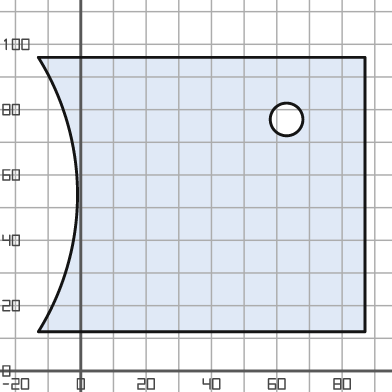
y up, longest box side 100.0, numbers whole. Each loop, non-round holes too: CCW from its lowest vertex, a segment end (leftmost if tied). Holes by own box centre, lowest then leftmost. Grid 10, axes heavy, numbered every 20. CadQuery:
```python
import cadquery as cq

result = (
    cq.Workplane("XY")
    .moveTo(-13.0, 12.0)
    .lineTo(87.0, 12.0)
    .lineTo(87.0, 96.0)
    .lineTo(-13.0, 96.0)
    .threePointArc((-1.0, 54.0), (-13.0, 12.0))
    .close()
    .moveTo(63.0, 77.0)
    .circle(5.0)
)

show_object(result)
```